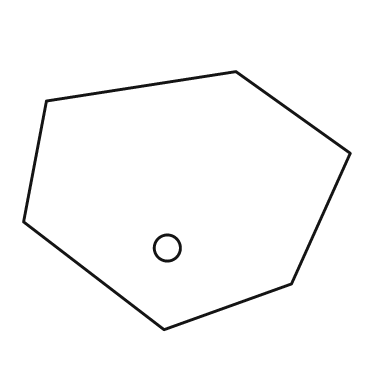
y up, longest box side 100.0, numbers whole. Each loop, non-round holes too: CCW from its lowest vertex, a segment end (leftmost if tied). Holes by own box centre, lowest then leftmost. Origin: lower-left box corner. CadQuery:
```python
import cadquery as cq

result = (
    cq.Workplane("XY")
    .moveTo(43.0, 0.0)
    .lineTo(82.0, 14.0)
    .lineTo(100.0, 54.0)
    .lineTo(65.0, 79.0)
    .lineTo(7.0, 70.0)
    .lineTo(0.0, 33.0)
    .close()
    .moveTo(44.0, 25.0)
    .circle(4.0)
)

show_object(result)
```